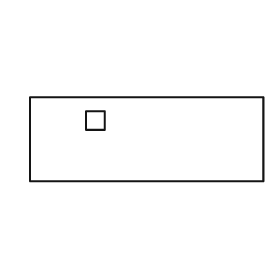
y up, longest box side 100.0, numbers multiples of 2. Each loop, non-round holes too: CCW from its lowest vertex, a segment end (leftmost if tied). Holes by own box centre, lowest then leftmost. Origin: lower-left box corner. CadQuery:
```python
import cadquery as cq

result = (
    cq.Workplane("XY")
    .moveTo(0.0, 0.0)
    .lineTo(100.0, 0.0)
    .lineTo(100.0, 36.0)
    .lineTo(0.0, 36.0)
    .close()
    .moveTo(24.0, 22.0)
    .lineTo(32.0, 22.0)
    .lineTo(32.0, 30.0)
    .lineTo(24.0, 30.0)
    .close()
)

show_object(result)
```